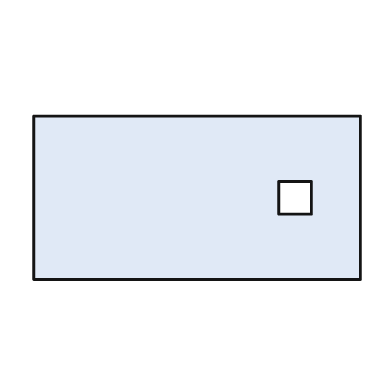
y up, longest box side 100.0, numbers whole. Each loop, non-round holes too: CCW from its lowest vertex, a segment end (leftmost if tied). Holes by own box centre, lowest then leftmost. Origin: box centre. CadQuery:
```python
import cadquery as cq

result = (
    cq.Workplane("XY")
    .moveTo(-50.0, -25.0)
    .lineTo(50.0, -25.0)
    .lineTo(50.0, 25.0)
    .lineTo(-50.0, 25.0)
    .close()
    .moveTo(25.0, -5.0)
    .lineTo(35.0, -5.0)
    .lineTo(35.0, 5.0)
    .lineTo(25.0, 5.0)
    .close()
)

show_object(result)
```